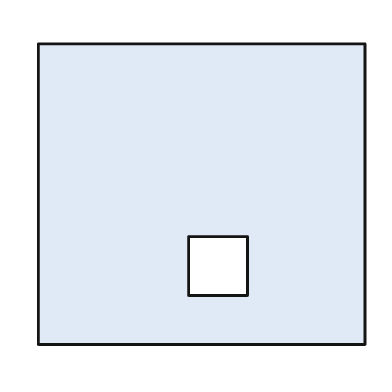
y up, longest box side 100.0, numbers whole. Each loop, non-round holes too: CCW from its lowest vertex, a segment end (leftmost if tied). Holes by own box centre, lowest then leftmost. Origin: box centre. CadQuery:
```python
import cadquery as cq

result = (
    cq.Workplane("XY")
    .moveTo(-50.0, -46.0)
    .lineTo(50.0, -46.0)
    .lineTo(50.0, 46.0)
    .lineTo(-50.0, 46.0)
    .close()
    .moveTo(-4.0, -31.0)
    .lineTo(14.0, -31.0)
    .lineTo(14.0, -13.0)
    .lineTo(-4.0, -13.0)
    .close()
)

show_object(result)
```